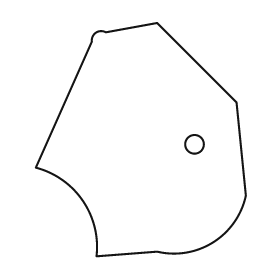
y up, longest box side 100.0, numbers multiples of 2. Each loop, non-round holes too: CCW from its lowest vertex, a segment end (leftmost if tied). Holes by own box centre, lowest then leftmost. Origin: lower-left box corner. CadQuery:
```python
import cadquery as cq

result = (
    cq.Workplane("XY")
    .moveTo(26.0, 0.0)
    .lineTo(52.0, 2.0)
    .threePointArc((76.0, 6.0), (90.0, 26.0))
    .lineTo(86.0, 66.0)
    .lineTo(52.0, 100.0)
    .lineTo(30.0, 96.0)
    .threePointArc((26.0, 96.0), (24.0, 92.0))
    .lineTo(0.0, 38.0)
    .threePointArc((20.0, 24.0), (26.0, 0.0))
    .close()
    .moveTo(68.0, 48.0)
    .circle(4.0)
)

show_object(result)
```